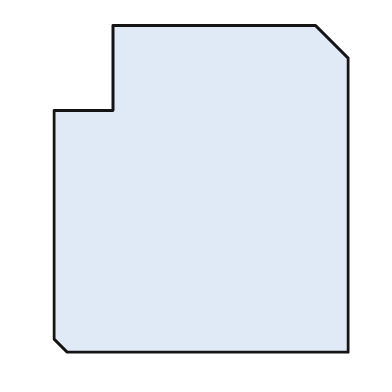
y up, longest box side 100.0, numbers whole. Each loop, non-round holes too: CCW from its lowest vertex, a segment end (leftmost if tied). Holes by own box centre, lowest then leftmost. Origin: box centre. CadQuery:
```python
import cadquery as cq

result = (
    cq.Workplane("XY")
    .moveTo(-41.0, -50.0)
    .lineTo(45.0, -50.0)
    .lineTo(45.0, 40.0)
    .lineTo(35.0, 50.0)
    .lineTo(-27.0, 50.0)
    .lineTo(-27.0, 24.0)
    .lineTo(-45.0, 24.0)
    .lineTo(-45.0, -46.0)
    .close()
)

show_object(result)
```